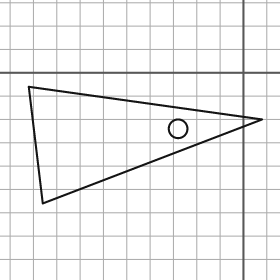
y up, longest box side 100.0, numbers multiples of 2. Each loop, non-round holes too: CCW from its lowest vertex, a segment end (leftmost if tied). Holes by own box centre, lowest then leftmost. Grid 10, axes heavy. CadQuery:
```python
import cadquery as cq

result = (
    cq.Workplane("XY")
    .moveTo(-86.0, -56.0)
    .lineTo(8.0, -20.0)
    .lineTo(-92.0, -6.0)
    .close()
    .moveTo(-28.0, -24.0)
    .circle(4.0)
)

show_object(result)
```